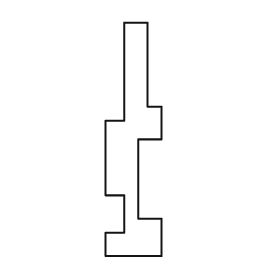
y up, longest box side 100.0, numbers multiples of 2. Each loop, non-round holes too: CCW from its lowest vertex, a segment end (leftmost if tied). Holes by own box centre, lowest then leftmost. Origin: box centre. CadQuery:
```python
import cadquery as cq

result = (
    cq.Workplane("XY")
    .moveTo(-12.0, -50.0)
    .lineTo(12.0, -50.0)
    .lineTo(12.0, -34.0)
    .lineTo(2.0, -34.0)
    .lineTo(2.0, 0.0)
    .lineTo(12.0, 0.0)
    .lineTo(12.0, 14.0)
    .lineTo(6.0, 14.0)
    .lineTo(6.0, 50.0)
    .lineTo(-4.0, 50.0)
    .lineTo(-4.0, 8.0)
    .lineTo(-12.0, 8.0)
    .lineTo(-12.0, -24.0)
    .lineTo(-4.0, -24.0)
    .lineTo(-4.0, -40.0)
    .lineTo(-12.0, -40.0)
    .close()
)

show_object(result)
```